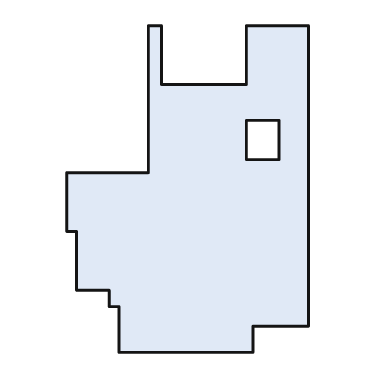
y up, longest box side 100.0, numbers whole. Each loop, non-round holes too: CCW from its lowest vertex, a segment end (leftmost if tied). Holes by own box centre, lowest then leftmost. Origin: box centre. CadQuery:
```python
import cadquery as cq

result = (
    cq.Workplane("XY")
    .moveTo(-21.0, -50.0)
    .lineTo(20.0, -50.0)
    .lineTo(20.0, -42.0)
    .lineTo(37.0, -42.0)
    .lineTo(37.0, 50.0)
    .lineTo(18.0, 50.0)
    .lineTo(18.0, 32.0)
    .lineTo(-8.0, 32.0)
    .lineTo(-8.0, 50.0)
    .lineTo(-12.0, 50.0)
    .lineTo(-12.0, 5.0)
    .lineTo(-37.0, 5.0)
    .lineTo(-37.0, -13.0)
    .lineTo(-34.0, -13.0)
    .lineTo(-34.0, -31.0)
    .lineTo(-24.0, -31.0)
    .lineTo(-24.0, -36.0)
    .lineTo(-21.0, -36.0)
    .close()
    .moveTo(18.0, 9.0)
    .lineTo(28.0, 9.0)
    .lineTo(28.0, 21.0)
    .lineTo(18.0, 21.0)
    .close()
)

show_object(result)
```